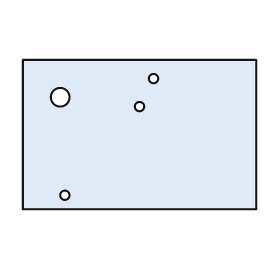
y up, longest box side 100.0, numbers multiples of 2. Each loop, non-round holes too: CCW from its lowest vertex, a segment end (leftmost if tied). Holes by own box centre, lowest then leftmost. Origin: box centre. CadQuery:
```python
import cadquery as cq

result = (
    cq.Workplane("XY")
    .moveTo(-50.0, -32.0)
    .lineTo(50.0, -32.0)
    .lineTo(50.0, 32.0)
    .lineTo(-50.0, 32.0)
    .close()
    .moveTo(-32.0, -26.0)
    .circle(2.0)
    .moveTo(0.0, 12.0)
    .circle(2.0)
    .moveTo(-34.0, 16.0)
    .circle(4.0)
    .moveTo(6.0, 24.0)
    .circle(2.0)
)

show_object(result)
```